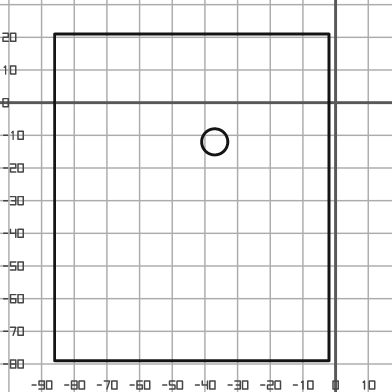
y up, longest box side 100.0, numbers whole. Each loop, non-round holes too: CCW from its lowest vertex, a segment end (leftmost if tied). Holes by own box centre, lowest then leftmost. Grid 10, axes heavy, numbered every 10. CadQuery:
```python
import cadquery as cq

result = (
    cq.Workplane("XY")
    .moveTo(-86.0, -79.0)
    .lineTo(-2.0, -79.0)
    .lineTo(-2.0, 21.0)
    .lineTo(-86.0, 21.0)
    .close()
    .moveTo(-37.0, -12.0)
    .circle(4.0)
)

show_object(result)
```